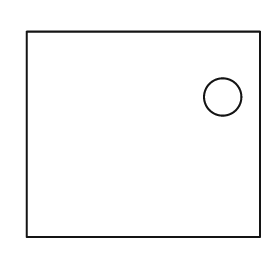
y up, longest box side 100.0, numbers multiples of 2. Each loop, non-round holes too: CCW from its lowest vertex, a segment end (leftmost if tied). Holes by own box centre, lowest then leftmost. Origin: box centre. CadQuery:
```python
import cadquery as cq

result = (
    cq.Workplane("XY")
    .moveTo(-50.0, -44.0)
    .lineTo(50.0, -44.0)
    .lineTo(50.0, 44.0)
    .lineTo(-50.0, 44.0)
    .close()
    .moveTo(34.0, 16.0)
    .circle(8.0)
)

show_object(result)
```